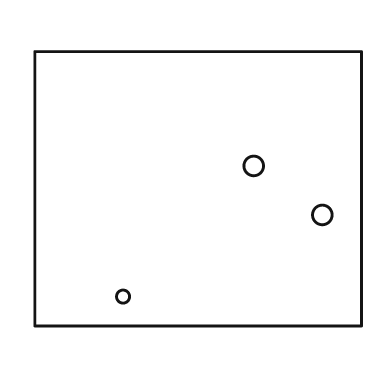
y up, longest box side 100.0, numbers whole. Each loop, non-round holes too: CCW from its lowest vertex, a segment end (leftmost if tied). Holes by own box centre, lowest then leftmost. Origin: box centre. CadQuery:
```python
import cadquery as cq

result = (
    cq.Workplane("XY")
    .moveTo(-50.0, -42.0)
    .lineTo(50.0, -42.0)
    .lineTo(50.0, 42.0)
    .lineTo(-50.0, 42.0)
    .close()
    .moveTo(-23.0, -33.0)
    .circle(2.0)
    .moveTo(38.0, -8.0)
    .circle(3.0)
    .moveTo(17.0, 7.0)
    .circle(3.0)
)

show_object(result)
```